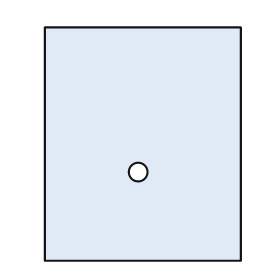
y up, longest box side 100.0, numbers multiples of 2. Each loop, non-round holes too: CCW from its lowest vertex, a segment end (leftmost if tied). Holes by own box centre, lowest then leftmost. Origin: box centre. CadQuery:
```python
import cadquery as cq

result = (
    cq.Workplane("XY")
    .moveTo(-42.0, -50.0)
    .lineTo(42.0, -50.0)
    .lineTo(42.0, 50.0)
    .lineTo(-42.0, 50.0)
    .close()
    .moveTo(-2.0, -12.0)
    .circle(4.0)
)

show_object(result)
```